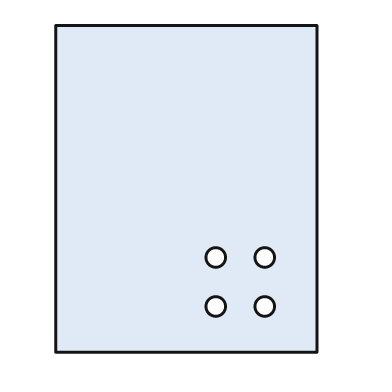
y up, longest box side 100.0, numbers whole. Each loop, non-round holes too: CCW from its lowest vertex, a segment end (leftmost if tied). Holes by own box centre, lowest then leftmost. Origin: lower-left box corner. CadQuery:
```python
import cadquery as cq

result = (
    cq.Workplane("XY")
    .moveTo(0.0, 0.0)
    .lineTo(80.0, 0.0)
    .lineTo(80.0, 100.0)
    .lineTo(0.0, 100.0)
    .close()
    .moveTo(49.0, 14.0)
    .circle(3.0)
    .moveTo(64.0, 14.0)
    .circle(3.0)
    .moveTo(49.0, 29.0)
    .circle(3.0)
    .moveTo(64.0, 29.0)
    .circle(3.0)
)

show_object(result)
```